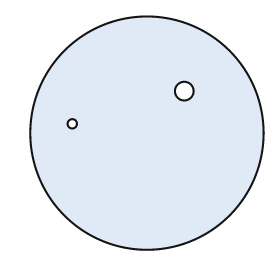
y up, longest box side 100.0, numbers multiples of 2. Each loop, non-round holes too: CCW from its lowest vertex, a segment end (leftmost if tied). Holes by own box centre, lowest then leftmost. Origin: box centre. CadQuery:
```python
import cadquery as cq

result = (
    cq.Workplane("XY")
    .moveTo(0.0, 0.0)
    .circle(50.0)
    .moveTo(-32.0, 4.0)
    .circle(2.0)
    .moveTo(16.0, 18.0)
    .circle(4.0)
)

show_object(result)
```